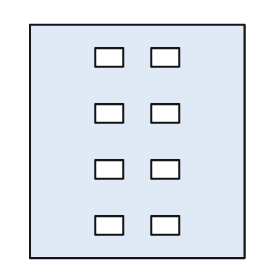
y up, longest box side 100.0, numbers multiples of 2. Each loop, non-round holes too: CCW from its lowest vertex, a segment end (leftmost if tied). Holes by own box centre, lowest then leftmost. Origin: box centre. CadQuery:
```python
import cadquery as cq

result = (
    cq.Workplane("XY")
    .moveTo(-46.0, -50.0)
    .lineTo(46.0, -50.0)
    .lineTo(46.0, 50.0)
    .lineTo(-46.0, 50.0)
    .close()
    .moveTo(-18.0, -40.0)
    .lineTo(-6.0, -40.0)
    .lineTo(-6.0, -32.0)
    .lineTo(-18.0, -32.0)
    .close()
    .moveTo(6.0, -40.0)
    .lineTo(18.0, -40.0)
    .lineTo(18.0, -32.0)
    .lineTo(6.0, -32.0)
    .close()
    .moveTo(-18.0, -16.0)
    .lineTo(-6.0, -16.0)
    .lineTo(-6.0, -8.0)
    .lineTo(-18.0, -8.0)
    .close()
    .moveTo(6.0, -16.0)
    .lineTo(18.0, -16.0)
    .lineTo(18.0, -8.0)
    .lineTo(6.0, -8.0)
    .close()
    .moveTo(-18.0, 8.0)
    .lineTo(-6.0, 8.0)
    .lineTo(-6.0, 16.0)
    .lineTo(-18.0, 16.0)
    .close()
    .moveTo(6.0, 8.0)
    .lineTo(18.0, 8.0)
    .lineTo(18.0, 16.0)
    .lineTo(6.0, 16.0)
    .close()
    .moveTo(-18.0, 32.0)
    .lineTo(-6.0, 32.0)
    .lineTo(-6.0, 40.0)
    .lineTo(-18.0, 40.0)
    .close()
    .moveTo(6.0, 32.0)
    .lineTo(18.0, 32.0)
    .lineTo(18.0, 40.0)
    .lineTo(6.0, 40.0)
    .close()
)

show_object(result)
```